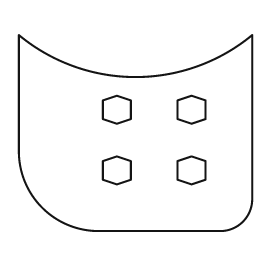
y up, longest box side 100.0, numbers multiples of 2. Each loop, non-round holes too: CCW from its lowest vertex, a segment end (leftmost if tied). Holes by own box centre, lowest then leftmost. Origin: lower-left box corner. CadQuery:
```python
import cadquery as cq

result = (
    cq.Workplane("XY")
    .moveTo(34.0, 0.0)
    .lineTo(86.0, 0.0)
    .threePointArc((96.0, 4.0), (100.0, 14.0))
    .lineTo(100.0, 84.0)
    .threePointArc((50.0, 66.0), (0.0, 84.0))
    .lineTo(0.0, 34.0)
    .threePointArc((10.0, 10.0), (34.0, 0.0))
    .close()
    .moveTo(42.0, 20.0)
    .lineTo(48.0, 22.0)
    .lineTo(48.0, 30.0)
    .lineTo(42.0, 32.0)
    .lineTo(36.0, 30.0)
    .lineTo(36.0, 22.0)
    .close()
    .moveTo(74.0, 20.0)
    .lineTo(80.0, 22.0)
    .lineTo(80.0, 30.0)
    .lineTo(74.0, 32.0)
    .lineTo(68.0, 30.0)
    .lineTo(68.0, 22.0)
    .close()
    .moveTo(42.0, 46.0)
    .lineTo(48.0, 48.0)
    .lineTo(48.0, 56.0)
    .lineTo(42.0, 58.0)
    .lineTo(36.0, 56.0)
    .lineTo(36.0, 48.0)
    .close()
    .moveTo(74.0, 46.0)
    .lineTo(80.0, 48.0)
    .lineTo(80.0, 56.0)
    .lineTo(74.0, 58.0)
    .lineTo(68.0, 56.0)
    .lineTo(68.0, 48.0)
    .close()
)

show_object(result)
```